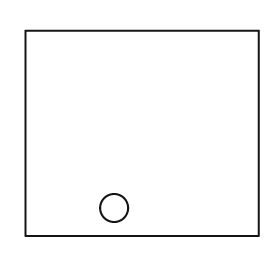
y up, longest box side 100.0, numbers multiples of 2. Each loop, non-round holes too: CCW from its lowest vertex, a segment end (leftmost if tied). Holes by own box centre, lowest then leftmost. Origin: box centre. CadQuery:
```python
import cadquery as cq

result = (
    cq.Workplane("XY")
    .moveTo(-50.0, -44.0)
    .lineTo(50.0, -44.0)
    .lineTo(50.0, 44.0)
    .lineTo(-50.0, 44.0)
    .close()
    .moveTo(-12.0, -32.0)
    .circle(6.0)
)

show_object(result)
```